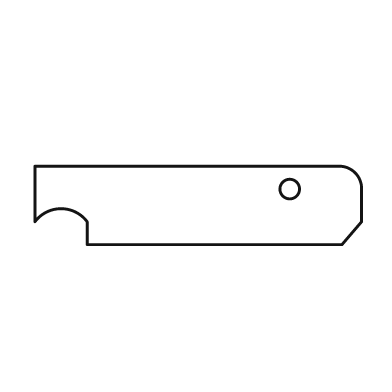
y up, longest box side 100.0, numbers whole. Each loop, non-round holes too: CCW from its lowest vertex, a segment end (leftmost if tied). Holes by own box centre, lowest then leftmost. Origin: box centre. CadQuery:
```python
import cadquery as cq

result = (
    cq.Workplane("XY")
    .moveTo(-34.0, -12.0)
    .lineTo(44.0, -12.0)
    .lineTo(50.0, -5.0)
    .lineTo(50.0, 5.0)
    .threePointArc((48.0, 10.0), (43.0, 12.0))
    .lineTo(-50.0, 12.0)
    .lineTo(-50.0, -5.0)
    .threePointArc((-42.0, -1.0), (-34.0, -5.0))
    .close()
    .moveTo(28.0, 5.0)
    .circle(3.0)
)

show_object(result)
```